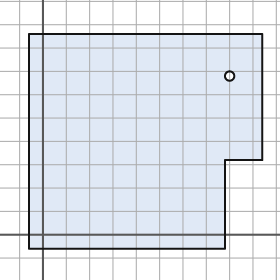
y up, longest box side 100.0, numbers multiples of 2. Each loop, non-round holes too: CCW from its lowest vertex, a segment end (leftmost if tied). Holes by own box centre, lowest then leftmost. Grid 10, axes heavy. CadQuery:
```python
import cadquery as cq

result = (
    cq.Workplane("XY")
    .moveTo(-6.0, -6.0)
    .lineTo(78.0, -6.0)
    .lineTo(78.0, 32.0)
    .lineTo(94.0, 32.0)
    .lineTo(94.0, 86.0)
    .lineTo(-6.0, 86.0)
    .close()
    .moveTo(80.0, 68.0)
    .circle(2.0)
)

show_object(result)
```